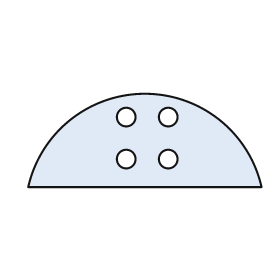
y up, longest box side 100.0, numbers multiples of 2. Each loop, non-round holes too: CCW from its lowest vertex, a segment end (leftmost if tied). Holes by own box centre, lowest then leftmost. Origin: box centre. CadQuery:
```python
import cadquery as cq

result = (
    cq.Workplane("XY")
    .moveTo(-50.0, -20.0)
    .lineTo(50.0, -20.0)
    .threePointArc((0.0, 20.0), (-50.0, -20.0))
    .close()
    .moveTo(-8.0, -8.0)
    .circle(4.0)
    .moveTo(10.0, -8.0)
    .circle(4.0)
    .moveTo(-8.0, 10.0)
    .circle(4.0)
    .moveTo(10.0, 10.0)
    .circle(4.0)
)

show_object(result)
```